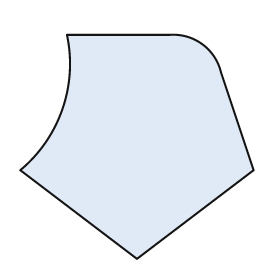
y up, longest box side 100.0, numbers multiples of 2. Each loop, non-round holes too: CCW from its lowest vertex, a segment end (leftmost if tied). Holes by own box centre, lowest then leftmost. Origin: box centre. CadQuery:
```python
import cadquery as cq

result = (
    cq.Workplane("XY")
    .moveTo(0.0, -48.0)
    .lineTo(50.0, -10.0)
    .lineTo(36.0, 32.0)
    .threePointArc((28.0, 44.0), (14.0, 48.0))
    .lineTo(-30.0, 48.0)
    .threePointArc((-32.0, 16.0), (-50.0, -10.0))
    .close()
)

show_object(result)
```